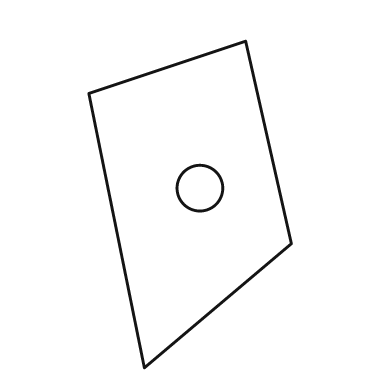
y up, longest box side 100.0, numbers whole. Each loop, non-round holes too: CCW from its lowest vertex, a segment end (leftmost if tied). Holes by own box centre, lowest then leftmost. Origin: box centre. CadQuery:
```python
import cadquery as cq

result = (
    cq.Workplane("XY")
    .moveTo(-14.0, -50.0)
    .lineTo(31.0, -12.0)
    .lineTo(17.0, 50.0)
    .lineTo(-31.0, 34.0)
    .close()
    .moveTo(3.0, 5.0)
    .circle(7.0)
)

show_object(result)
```